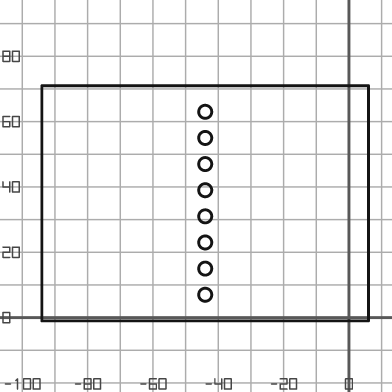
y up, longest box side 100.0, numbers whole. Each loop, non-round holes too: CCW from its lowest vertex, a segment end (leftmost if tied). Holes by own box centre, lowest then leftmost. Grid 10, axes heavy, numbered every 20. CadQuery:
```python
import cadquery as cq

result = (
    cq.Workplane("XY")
    .moveTo(-94.0, -1.0)
    .lineTo(6.0, -1.0)
    .lineTo(6.0, 71.0)
    .lineTo(-94.0, 71.0)
    .close()
    .moveTo(-44.0, 7.0)
    .circle(2.0)
    .moveTo(-44.0, 15.0)
    .circle(2.0)
    .moveTo(-44.0, 23.0)
    .circle(2.0)
    .moveTo(-44.0, 31.0)
    .circle(2.0)
    .moveTo(-44.0, 39.0)
    .circle(2.0)
    .moveTo(-44.0, 47.0)
    .circle(2.0)
    .moveTo(-44.0, 55.0)
    .circle(2.0)
    .moveTo(-44.0, 63.0)
    .circle(2.0)
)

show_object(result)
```